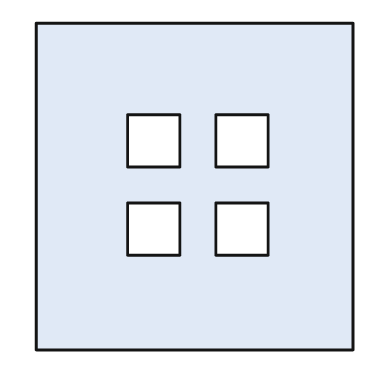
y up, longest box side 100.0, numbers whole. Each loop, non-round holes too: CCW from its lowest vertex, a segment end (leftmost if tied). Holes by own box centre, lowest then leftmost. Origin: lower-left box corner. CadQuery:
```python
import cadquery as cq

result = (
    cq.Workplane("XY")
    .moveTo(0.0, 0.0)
    .lineTo(97.0, 0.0)
    .lineTo(97.0, 100.0)
    .lineTo(0.0, 100.0)
    .close()
    .moveTo(28.0, 29.0)
    .lineTo(44.0, 29.0)
    .lineTo(44.0, 45.0)
    .lineTo(28.0, 45.0)
    .close()
    .moveTo(55.0, 29.0)
    .lineTo(71.0, 29.0)
    .lineTo(71.0, 45.0)
    .lineTo(55.0, 45.0)
    .close()
    .moveTo(28.0, 56.0)
    .lineTo(44.0, 56.0)
    .lineTo(44.0, 72.0)
    .lineTo(28.0, 72.0)
    .close()
    .moveTo(55.0, 56.0)
    .lineTo(71.0, 56.0)
    .lineTo(71.0, 72.0)
    .lineTo(55.0, 72.0)
    .close()
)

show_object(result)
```